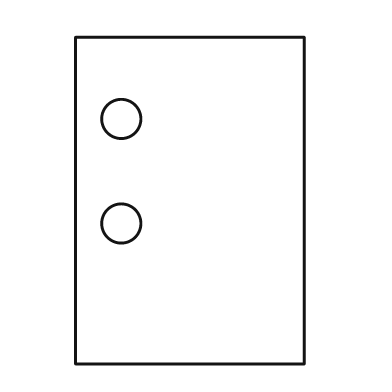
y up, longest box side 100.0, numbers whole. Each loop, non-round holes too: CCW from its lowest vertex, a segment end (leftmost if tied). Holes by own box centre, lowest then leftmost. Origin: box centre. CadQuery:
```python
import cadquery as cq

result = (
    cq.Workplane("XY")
    .moveTo(-35.0, -50.0)
    .lineTo(35.0, -50.0)
    .lineTo(35.0, 50.0)
    .lineTo(-35.0, 50.0)
    .close()
    .moveTo(-21.0, -7.0)
    .circle(6.0)
    .moveTo(-21.0, 25.0)
    .circle(6.0)
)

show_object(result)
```